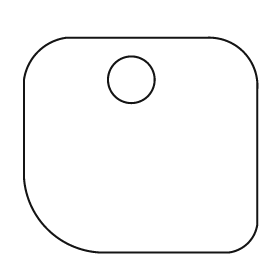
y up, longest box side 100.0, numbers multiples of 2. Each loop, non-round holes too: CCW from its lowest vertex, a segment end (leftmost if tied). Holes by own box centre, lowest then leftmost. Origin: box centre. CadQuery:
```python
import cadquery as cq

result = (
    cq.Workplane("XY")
    .moveTo(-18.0, -46.0)
    .lineTo(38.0, -46.0)
    .threePointArc((46.0, -42.0), (50.0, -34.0))
    .lineTo(50.0, 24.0)
    .threePointArc((44.0, 40.0), (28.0, 46.0))
    .lineTo(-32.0, 46.0)
    .threePointArc((-44.0, 40.0), (-50.0, 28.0))
    .lineTo(-50.0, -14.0)
    .threePointArc((-40.0, -36.0), (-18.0, -46.0))
    .close()
    .moveTo(-4.0, 28.0)
    .circle(10.0)
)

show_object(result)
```